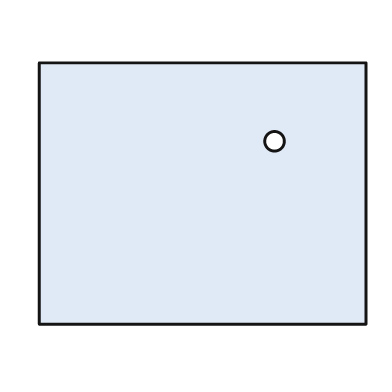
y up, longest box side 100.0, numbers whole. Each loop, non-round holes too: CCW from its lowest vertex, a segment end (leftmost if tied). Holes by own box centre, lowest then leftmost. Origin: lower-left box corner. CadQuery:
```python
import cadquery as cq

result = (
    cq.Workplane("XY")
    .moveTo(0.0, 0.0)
    .lineTo(100.0, 0.0)
    .lineTo(100.0, 80.0)
    .lineTo(0.0, 80.0)
    .close()
    .moveTo(72.0, 56.0)
    .circle(3.0)
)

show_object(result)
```